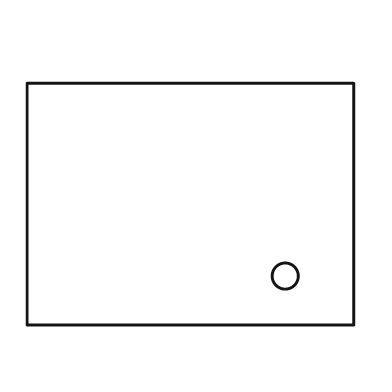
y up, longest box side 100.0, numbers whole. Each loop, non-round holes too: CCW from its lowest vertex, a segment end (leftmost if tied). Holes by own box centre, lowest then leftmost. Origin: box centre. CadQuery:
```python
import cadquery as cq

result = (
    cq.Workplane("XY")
    .moveTo(-50.0, -37.0)
    .lineTo(50.0, -37.0)
    .lineTo(50.0, 37.0)
    .lineTo(-50.0, 37.0)
    .close()
    .moveTo(29.0, -22.0)
    .circle(4.0)
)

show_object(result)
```